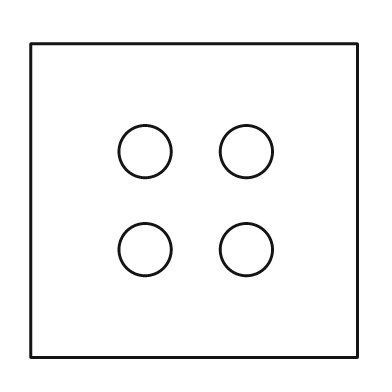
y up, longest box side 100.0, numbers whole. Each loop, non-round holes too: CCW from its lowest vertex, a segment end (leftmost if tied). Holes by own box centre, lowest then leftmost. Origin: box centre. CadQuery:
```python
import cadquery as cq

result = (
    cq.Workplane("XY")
    .moveTo(-50.0, -48.0)
    .lineTo(50.0, -48.0)
    .lineTo(50.0, 48.0)
    .lineTo(-50.0, 48.0)
    .close()
    .moveTo(-15.0, -15.0)
    .circle(8.0)
    .moveTo(16.0, -15.0)
    .circle(8.0)
    .moveTo(-15.0, 15.0)
    .circle(8.0)
    .moveTo(16.0, 15.0)
    .circle(8.0)
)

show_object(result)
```